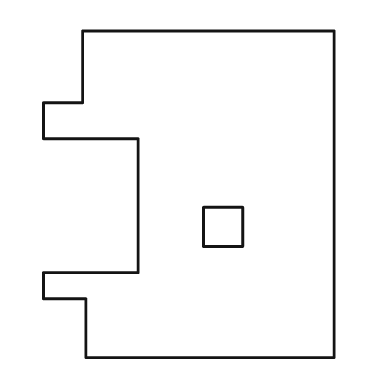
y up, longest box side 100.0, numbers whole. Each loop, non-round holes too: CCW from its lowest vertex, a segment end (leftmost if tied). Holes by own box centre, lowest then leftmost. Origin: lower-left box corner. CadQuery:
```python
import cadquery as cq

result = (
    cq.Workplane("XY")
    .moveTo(13.0, 0.0)
    .lineTo(89.0, 0.0)
    .lineTo(89.0, 100.0)
    .lineTo(12.0, 100.0)
    .lineTo(12.0, 78.0)
    .lineTo(0.0, 78.0)
    .lineTo(0.0, 67.0)
    .lineTo(29.0, 67.0)
    .lineTo(29.0, 26.0)
    .lineTo(0.0, 26.0)
    .lineTo(0.0, 18.0)
    .lineTo(13.0, 18.0)
    .close()
    .moveTo(49.0, 34.0)
    .lineTo(61.0, 34.0)
    .lineTo(61.0, 46.0)
    .lineTo(49.0, 46.0)
    .close()
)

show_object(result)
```